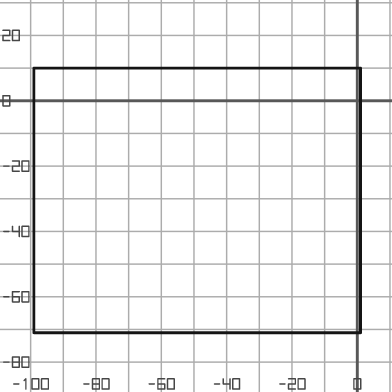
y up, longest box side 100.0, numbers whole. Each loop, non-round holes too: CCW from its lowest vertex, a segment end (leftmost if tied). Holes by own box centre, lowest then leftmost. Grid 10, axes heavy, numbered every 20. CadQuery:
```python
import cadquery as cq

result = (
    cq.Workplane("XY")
    .moveTo(-99.0, -71.0)
    .lineTo(1.0, -71.0)
    .lineTo(1.0, 10.0)
    .lineTo(-99.0, 10.0)
    .close()
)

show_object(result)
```